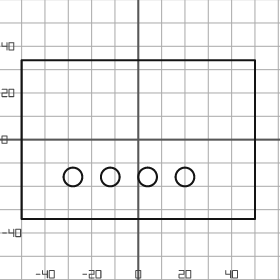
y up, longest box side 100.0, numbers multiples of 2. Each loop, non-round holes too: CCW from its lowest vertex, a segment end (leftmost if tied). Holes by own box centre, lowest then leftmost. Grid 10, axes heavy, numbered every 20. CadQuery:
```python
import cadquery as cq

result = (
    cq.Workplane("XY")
    .moveTo(-50.0, -34.0)
    .lineTo(50.0, -34.0)
    .lineTo(50.0, 34.0)
    .lineTo(-50.0, 34.0)
    .close()
    .moveTo(-28.0, -16.0)
    .circle(4.0)
    .moveTo(-12.0, -16.0)
    .circle(4.0)
    .moveTo(4.0, -16.0)
    .circle(4.0)
    .moveTo(20.0, -16.0)
    .circle(4.0)
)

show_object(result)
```